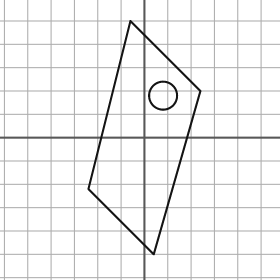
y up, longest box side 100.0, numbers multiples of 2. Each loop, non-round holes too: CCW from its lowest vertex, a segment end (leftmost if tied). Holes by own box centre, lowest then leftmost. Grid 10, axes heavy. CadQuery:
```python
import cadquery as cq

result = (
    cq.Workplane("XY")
    .moveTo(4.0, -50.0)
    .lineTo(24.0, 20.0)
    .lineTo(-6.0, 50.0)
    .lineTo(-24.0, -22.0)
    .close()
    .moveTo(8.0, 18.0)
    .circle(6.0)
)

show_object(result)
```